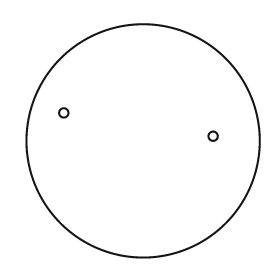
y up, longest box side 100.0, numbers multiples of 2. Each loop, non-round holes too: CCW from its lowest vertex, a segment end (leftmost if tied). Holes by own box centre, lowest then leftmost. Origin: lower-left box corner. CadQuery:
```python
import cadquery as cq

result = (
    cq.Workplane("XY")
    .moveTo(50.0, 50.0)
    .circle(50.0)
    .moveTo(80.0, 52.0)
    .circle(2.0)
    .moveTo(16.0, 62.0)
    .circle(2.0)
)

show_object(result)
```